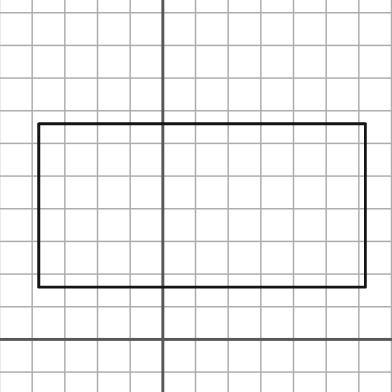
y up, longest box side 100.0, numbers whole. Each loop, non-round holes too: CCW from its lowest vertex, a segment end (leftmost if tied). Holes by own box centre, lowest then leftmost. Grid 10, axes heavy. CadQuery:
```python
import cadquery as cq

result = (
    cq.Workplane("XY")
    .moveTo(-38.0, 16.0)
    .lineTo(62.0, 16.0)
    .lineTo(62.0, 66.0)
    .lineTo(-38.0, 66.0)
    .close()
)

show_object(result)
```